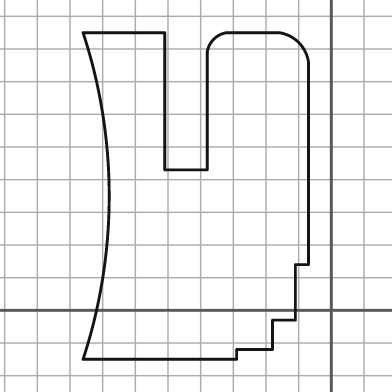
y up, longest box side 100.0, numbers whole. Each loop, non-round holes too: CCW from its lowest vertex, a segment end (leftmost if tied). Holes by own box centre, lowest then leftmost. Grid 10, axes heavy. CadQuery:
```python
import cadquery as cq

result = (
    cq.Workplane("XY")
    .moveTo(-76.0, -15.0)
    .lineTo(-29.0, -15.0)
    .lineTo(-29.0, -12.0)
    .lineTo(-18.0, -12.0)
    .lineTo(-18.0, -3.0)
    .lineTo(-11.0, -3.0)
    .lineTo(-11.0, 14.0)
    .lineTo(-7.0, 14.0)
    .lineTo(-7.0, 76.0)
    .threePointArc((-10.0, 82.0), (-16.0, 85.0))
    .lineTo(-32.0, 85.0)
    .threePointArc((-36.0, 83.0), (-38.0, 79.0))
    .lineTo(-38.0, 43.0)
    .lineTo(-51.0, 43.0)
    .lineTo(-51.0, 85.0)
    .lineTo(-76.0, 85.0)
    .threePointArc((-68.0, 35.0), (-76.0, -15.0))
    .close()
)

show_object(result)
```